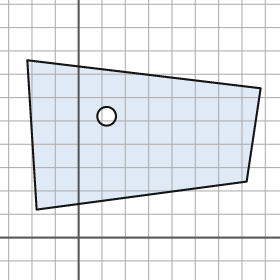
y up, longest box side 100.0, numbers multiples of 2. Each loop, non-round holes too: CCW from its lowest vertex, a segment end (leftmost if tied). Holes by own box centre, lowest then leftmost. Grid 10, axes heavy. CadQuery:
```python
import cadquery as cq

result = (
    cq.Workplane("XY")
    .moveTo(-18.0, 12.0)
    .lineTo(72.0, 24.0)
    .lineTo(78.0, 64.0)
    .lineTo(-22.0, 76.0)
    .close()
    .moveTo(12.0, 52.0)
    .circle(4.0)
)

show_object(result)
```